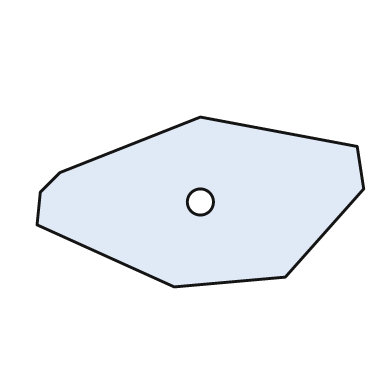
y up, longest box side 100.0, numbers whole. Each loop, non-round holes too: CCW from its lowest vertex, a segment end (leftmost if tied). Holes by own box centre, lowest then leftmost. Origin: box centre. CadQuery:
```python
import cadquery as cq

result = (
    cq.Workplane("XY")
    .moveTo(-8.0, -26.0)
    .lineTo(26.0, -23.0)
    .lineTo(50.0, 4.0)
    .lineTo(48.0, 17.0)
    .lineTo(0.0, 26.0)
    .lineTo(-43.0, 9.0)
    .lineTo(-49.0, 3.0)
    .lineTo(-50.0, -7.0)
    .close()
    .moveTo(0.0, 0.0)
    .circle(4.0)
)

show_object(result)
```